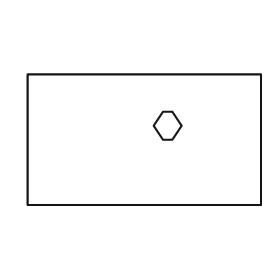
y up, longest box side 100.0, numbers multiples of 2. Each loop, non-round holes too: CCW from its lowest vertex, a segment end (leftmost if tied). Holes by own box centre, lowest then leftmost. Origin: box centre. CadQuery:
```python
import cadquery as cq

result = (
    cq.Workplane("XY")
    .moveTo(-50.0, -28.0)
    .lineTo(50.0, -28.0)
    .lineTo(50.0, 28.0)
    .lineTo(-50.0, 28.0)
    .close()
    .moveTo(8.0, 0.0)
    .lineTo(12.0, 0.0)
    .lineTo(16.0, 6.0)
    .lineTo(12.0, 12.0)
    .lineTo(8.0, 12.0)
    .lineTo(4.0, 6.0)
    .close()
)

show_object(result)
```